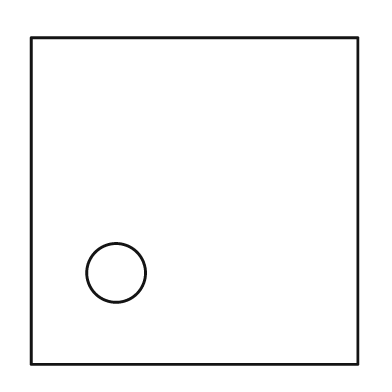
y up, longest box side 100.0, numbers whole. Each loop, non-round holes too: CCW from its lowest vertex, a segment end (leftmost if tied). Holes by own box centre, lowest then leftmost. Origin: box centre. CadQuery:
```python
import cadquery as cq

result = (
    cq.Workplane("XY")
    .moveTo(-50.0, -50.0)
    .lineTo(50.0, -50.0)
    .lineTo(50.0, 50.0)
    .lineTo(-50.0, 50.0)
    .close()
    .moveTo(-24.0, -22.0)
    .circle(9.0)
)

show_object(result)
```